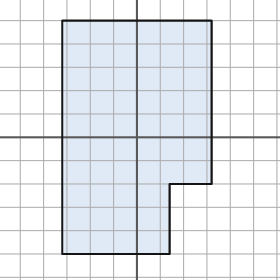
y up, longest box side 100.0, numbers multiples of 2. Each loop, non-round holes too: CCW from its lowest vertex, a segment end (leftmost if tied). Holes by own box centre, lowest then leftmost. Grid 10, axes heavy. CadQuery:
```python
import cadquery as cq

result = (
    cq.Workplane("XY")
    .moveTo(-32.0, -50.0)
    .lineTo(14.0, -50.0)
    .lineTo(14.0, -20.0)
    .lineTo(32.0, -20.0)
    .lineTo(32.0, 50.0)
    .lineTo(-32.0, 50.0)
    .close()
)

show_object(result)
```